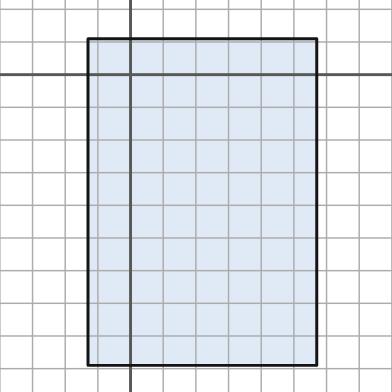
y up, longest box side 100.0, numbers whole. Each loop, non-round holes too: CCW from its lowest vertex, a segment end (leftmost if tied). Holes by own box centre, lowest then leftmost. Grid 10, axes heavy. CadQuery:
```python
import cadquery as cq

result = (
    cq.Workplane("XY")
    .moveTo(-13.0, -89.0)
    .lineTo(57.0, -89.0)
    .lineTo(57.0, 11.0)
    .lineTo(-13.0, 11.0)
    .close()
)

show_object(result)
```